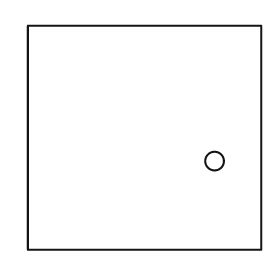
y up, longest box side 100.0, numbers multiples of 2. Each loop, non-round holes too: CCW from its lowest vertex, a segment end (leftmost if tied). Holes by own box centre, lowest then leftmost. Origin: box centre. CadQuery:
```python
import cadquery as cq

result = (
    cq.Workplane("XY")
    .moveTo(-50.0, -48.0)
    .lineTo(50.0, -48.0)
    .lineTo(50.0, 48.0)
    .lineTo(-50.0, 48.0)
    .close()
    .moveTo(30.0, -10.0)
    .circle(4.0)
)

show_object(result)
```